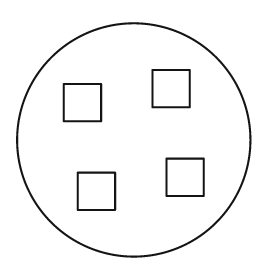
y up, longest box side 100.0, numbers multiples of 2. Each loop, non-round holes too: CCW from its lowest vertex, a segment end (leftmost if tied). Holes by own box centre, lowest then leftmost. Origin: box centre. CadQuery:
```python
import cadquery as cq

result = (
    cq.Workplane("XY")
    .moveTo(0.0, 0.0)
    .circle(50.0)
    .moveTo(-24.0, -30.0)
    .lineTo(-8.0, -30.0)
    .lineTo(-8.0, -14.0)
    .lineTo(-24.0, -14.0)
    .close()
    .moveTo(14.0, -24.0)
    .lineTo(30.0, -24.0)
    .lineTo(30.0, -8.0)
    .lineTo(14.0, -8.0)
    .close()
    .moveTo(-30.0, 8.0)
    .lineTo(-14.0, 8.0)
    .lineTo(-14.0, 24.0)
    .lineTo(-30.0, 24.0)
    .close()
    .moveTo(8.0, 14.0)
    .lineTo(24.0, 14.0)
    .lineTo(24.0, 30.0)
    .lineTo(8.0, 30.0)
    .close()
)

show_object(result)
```